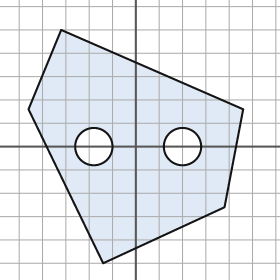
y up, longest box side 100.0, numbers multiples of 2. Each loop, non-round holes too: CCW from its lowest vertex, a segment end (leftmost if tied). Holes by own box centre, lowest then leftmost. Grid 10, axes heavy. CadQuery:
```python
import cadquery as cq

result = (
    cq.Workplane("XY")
    .moveTo(-14.0, -50.0)
    .lineTo(38.0, -26.0)
    .lineTo(46.0, 16.0)
    .lineTo(-32.0, 50.0)
    .lineTo(-46.0, 16.0)
    .close()
    .moveTo(-18.0, 0.0)
    .circle(8.0)
    .moveTo(20.0, 0.0)
    .circle(8.0)
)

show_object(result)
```